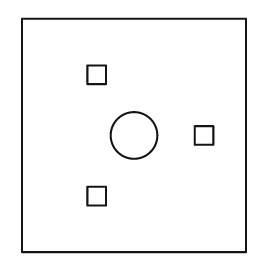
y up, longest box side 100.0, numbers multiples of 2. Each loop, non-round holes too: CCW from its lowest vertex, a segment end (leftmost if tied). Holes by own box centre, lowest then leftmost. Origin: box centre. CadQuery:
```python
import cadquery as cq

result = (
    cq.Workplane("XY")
    .moveTo(-48.0, -50.0)
    .lineTo(48.0, -50.0)
    .lineTo(48.0, 50.0)
    .lineTo(-48.0, 50.0)
    .close()
    .moveTo(-20.0, -30.0)
    .lineTo(-12.0, -30.0)
    .lineTo(-12.0, -22.0)
    .lineTo(-20.0, -22.0)
    .close()
    .moveTo(0.0, 0.0)
    .circle(10.0)
    .moveTo(26.0, -4.0)
    .lineTo(34.0, -4.0)
    .lineTo(34.0, 4.0)
    .lineTo(26.0, 4.0)
    .close()
    .moveTo(-20.0, 22.0)
    .lineTo(-12.0, 22.0)
    .lineTo(-12.0, 30.0)
    .lineTo(-20.0, 30.0)
    .close()
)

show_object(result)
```